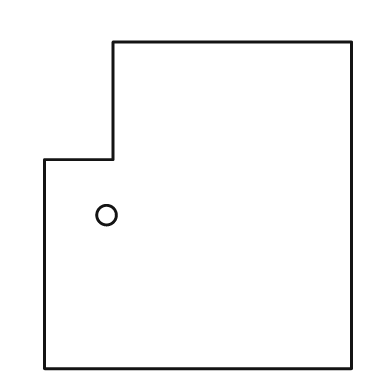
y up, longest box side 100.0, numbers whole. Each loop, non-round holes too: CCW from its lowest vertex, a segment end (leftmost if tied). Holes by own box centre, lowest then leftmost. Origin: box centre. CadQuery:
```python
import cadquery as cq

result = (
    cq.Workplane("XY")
    .moveTo(-47.0, -50.0)
    .lineTo(47.0, -50.0)
    .lineTo(47.0, 50.0)
    .lineTo(-26.0, 50.0)
    .lineTo(-26.0, 14.0)
    .lineTo(-47.0, 14.0)
    .close()
    .moveTo(-28.0, -3.0)
    .circle(3.0)
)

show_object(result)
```